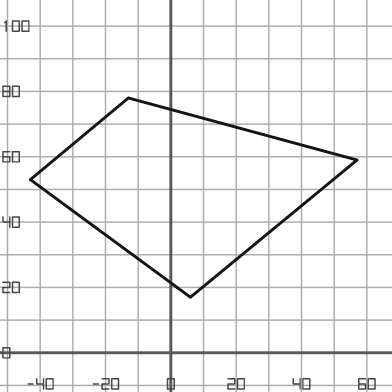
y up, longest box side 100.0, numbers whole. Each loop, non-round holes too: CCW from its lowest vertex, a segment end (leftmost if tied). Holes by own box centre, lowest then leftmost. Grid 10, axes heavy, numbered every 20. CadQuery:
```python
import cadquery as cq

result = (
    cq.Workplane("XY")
    .moveTo(6.0, 17.0)
    .lineTo(57.0, 59.0)
    .lineTo(-13.0, 78.0)
    .lineTo(-43.0, 53.0)
    .close()
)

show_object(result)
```